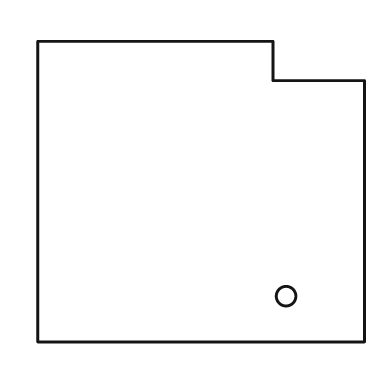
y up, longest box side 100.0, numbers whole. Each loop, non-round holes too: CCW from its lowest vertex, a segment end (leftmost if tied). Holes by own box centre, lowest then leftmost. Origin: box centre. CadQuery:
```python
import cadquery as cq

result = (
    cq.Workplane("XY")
    .moveTo(-50.0, -46.0)
    .lineTo(50.0, -46.0)
    .lineTo(50.0, 34.0)
    .lineTo(22.0, 34.0)
    .lineTo(22.0, 46.0)
    .lineTo(-50.0, 46.0)
    .close()
    .moveTo(26.0, -32.0)
    .circle(3.0)
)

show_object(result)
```